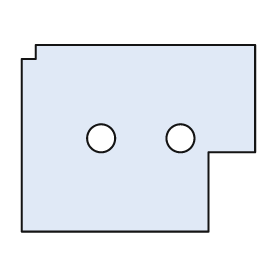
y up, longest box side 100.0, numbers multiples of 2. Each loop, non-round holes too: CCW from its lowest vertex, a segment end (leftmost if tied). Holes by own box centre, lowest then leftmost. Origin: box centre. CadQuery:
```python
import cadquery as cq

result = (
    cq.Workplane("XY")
    .moveTo(-50.0, -40.0)
    .lineTo(30.0, -40.0)
    .lineTo(30.0, -6.0)
    .lineTo(50.0, -6.0)
    .lineTo(50.0, 40.0)
    .lineTo(-44.0, 40.0)
    .lineTo(-44.0, 34.0)
    .lineTo(-50.0, 34.0)
    .close()
    .moveTo(-16.0, 0.0)
    .circle(6.0)
    .moveTo(18.0, 0.0)
    .circle(6.0)
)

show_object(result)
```